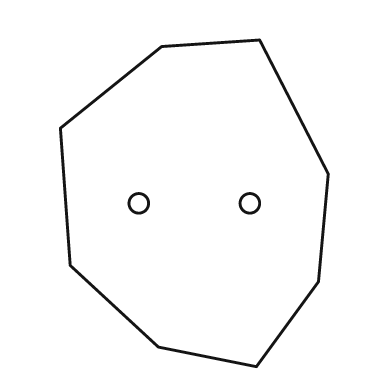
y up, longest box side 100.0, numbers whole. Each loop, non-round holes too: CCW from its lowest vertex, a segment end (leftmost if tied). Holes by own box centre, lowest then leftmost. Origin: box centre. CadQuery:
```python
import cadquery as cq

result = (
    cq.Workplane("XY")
    .moveTo(19.0, -50.0)
    .lineTo(38.0, -24.0)
    .lineTo(41.0, 9.0)
    .lineTo(20.0, 50.0)
    .lineTo(-10.0, 48.0)
    .lineTo(-41.0, 23.0)
    .lineTo(-38.0, -19.0)
    .lineTo(-11.0, -44.0)
    .close()
    .moveTo(-17.0, 0.0)
    .circle(3.0)
    .moveTo(17.0, 0.0)
    .circle(3.0)
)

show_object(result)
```